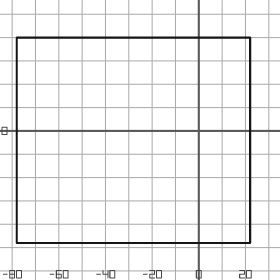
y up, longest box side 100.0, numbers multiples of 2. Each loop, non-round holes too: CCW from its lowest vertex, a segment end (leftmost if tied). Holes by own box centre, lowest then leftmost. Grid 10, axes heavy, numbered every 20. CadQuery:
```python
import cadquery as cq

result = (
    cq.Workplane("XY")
    .moveTo(-78.0, -48.0)
    .lineTo(22.0, -48.0)
    .lineTo(22.0, 40.0)
    .lineTo(-78.0, 40.0)
    .close()
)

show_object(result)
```